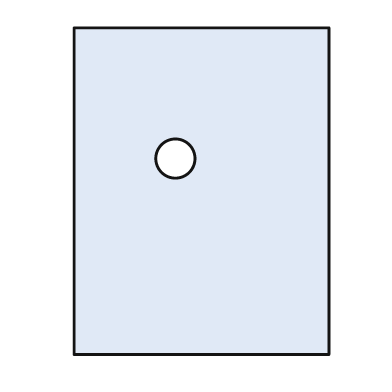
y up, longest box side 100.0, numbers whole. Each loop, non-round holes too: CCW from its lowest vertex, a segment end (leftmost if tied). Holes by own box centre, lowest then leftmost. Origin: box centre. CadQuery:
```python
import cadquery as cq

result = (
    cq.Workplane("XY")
    .moveTo(-39.0, -50.0)
    .lineTo(39.0, -50.0)
    .lineTo(39.0, 50.0)
    .lineTo(-39.0, 50.0)
    .close()
    .moveTo(-8.0, 10.0)
    .circle(6.0)
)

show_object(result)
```